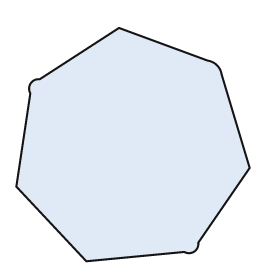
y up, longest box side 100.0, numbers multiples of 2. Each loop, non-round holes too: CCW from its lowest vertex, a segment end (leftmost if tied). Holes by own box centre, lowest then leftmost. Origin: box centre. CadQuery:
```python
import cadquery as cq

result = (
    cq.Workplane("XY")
    .moveTo(-20.0, -50.0)
    .lineTo(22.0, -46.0)
    .threePointArc((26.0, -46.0), (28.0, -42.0))
    .lineTo(50.0, -10.0)
    .lineTo(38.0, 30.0)
    .threePointArc((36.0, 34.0), (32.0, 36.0))
    .lineTo(-6.0, 50.0)
    .lineTo(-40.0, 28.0)
    .threePointArc((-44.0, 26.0), (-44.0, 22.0))
    .lineTo(-50.0, -18.0)
    .close()
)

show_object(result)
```